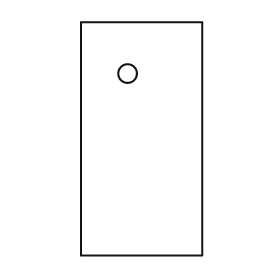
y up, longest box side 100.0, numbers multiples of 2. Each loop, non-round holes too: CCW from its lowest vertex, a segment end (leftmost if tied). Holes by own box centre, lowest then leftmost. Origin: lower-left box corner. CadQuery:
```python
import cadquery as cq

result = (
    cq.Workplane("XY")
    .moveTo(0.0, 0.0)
    .lineTo(52.0, 0.0)
    .lineTo(52.0, 100.0)
    .lineTo(0.0, 100.0)
    .close()
    .moveTo(20.0, 78.0)
    .circle(4.0)
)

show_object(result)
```